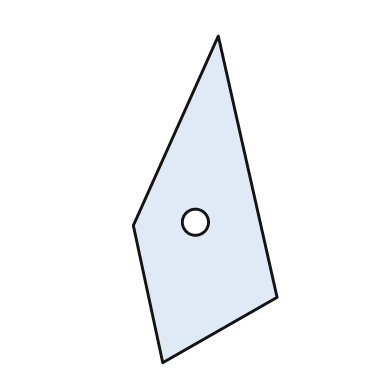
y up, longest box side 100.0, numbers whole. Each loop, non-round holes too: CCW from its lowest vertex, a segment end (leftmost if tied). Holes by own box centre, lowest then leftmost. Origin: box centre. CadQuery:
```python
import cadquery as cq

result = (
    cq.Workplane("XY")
    .moveTo(-13.0, -50.0)
    .lineTo(22.0, -30.0)
    .lineTo(4.0, 50.0)
    .lineTo(-22.0, -8.0)
    .close()
    .moveTo(-3.0, -7.0)
    .circle(4.0)
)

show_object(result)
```